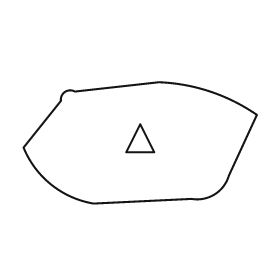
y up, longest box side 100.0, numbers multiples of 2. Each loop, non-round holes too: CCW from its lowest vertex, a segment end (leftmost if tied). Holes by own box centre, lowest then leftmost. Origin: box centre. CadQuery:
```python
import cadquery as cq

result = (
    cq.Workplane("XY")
    .moveTo(-20.0, -26.0)
    .lineTo(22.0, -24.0)
    .threePointArc((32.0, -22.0), (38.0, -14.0))
    .lineTo(50.0, 12.0)
    .threePointArc((30.0, 22.0), (8.0, 26.0))
    .lineTo(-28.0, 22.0)
    .threePointArc((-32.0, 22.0), (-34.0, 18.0))
    .lineTo(-50.0, -2.0)
    .threePointArc((-38.0, -18.0), (-20.0, -26.0))
    .close()
    .moveTo(-6.0, -4.0)
    .lineTo(6.0, -4.0)
    .lineTo(0.0, 8.0)
    .close()
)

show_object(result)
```